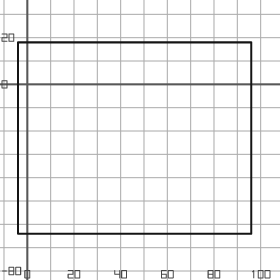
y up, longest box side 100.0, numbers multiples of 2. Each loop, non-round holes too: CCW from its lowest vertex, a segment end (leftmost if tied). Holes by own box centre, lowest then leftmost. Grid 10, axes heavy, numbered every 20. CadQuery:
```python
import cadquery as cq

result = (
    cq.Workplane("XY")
    .moveTo(-4.0, -64.0)
    .lineTo(96.0, -64.0)
    .lineTo(96.0, 18.0)
    .lineTo(-4.0, 18.0)
    .close()
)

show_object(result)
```